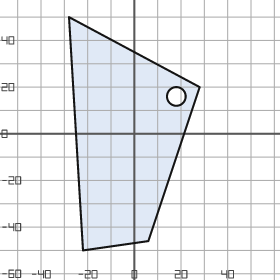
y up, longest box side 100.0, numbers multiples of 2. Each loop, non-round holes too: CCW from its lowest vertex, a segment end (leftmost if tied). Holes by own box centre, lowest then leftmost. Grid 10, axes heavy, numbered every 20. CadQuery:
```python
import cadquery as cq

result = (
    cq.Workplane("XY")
    .moveTo(-22.0, -50.0)
    .lineTo(6.0, -46.0)
    .lineTo(28.0, 20.0)
    .lineTo(-28.0, 50.0)
    .close()
    .moveTo(18.0, 16.0)
    .circle(4.0)
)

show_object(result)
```